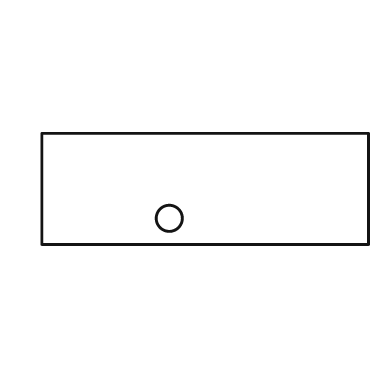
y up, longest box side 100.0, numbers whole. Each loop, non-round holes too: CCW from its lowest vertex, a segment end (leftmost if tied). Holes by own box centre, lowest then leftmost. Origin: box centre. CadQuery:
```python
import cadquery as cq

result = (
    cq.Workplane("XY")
    .moveTo(-50.0, -17.0)
    .lineTo(50.0, -17.0)
    .lineTo(50.0, 17.0)
    .lineTo(-50.0, 17.0)
    .close()
    .moveTo(-11.0, -9.0)
    .circle(4.0)
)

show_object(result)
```